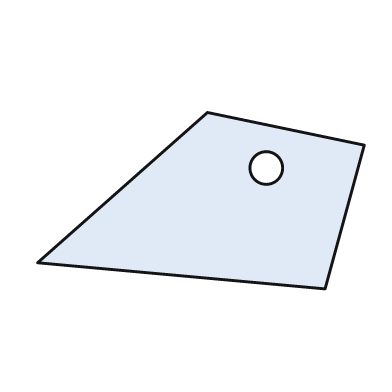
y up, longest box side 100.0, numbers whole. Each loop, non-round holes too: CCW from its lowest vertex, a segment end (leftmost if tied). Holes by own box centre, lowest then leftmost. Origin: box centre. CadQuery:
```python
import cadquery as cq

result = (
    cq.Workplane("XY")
    .moveTo(38.0, -27.0)
    .lineTo(50.0, 17.0)
    .lineTo(2.0, 27.0)
    .lineTo(-50.0, -19.0)
    .close()
    .moveTo(20.0, 10.0)
    .circle(5.0)
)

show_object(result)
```